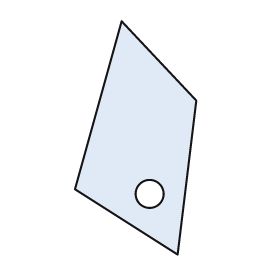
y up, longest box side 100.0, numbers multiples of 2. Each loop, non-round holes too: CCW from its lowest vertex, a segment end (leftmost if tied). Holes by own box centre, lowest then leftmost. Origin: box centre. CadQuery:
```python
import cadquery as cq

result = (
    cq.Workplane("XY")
    .moveTo(18.0, -50.0)
    .lineTo(26.0, 16.0)
    .lineTo(-6.0, 50.0)
    .lineTo(-26.0, -22.0)
    .close()
    .moveTo(6.0, -24.0)
    .circle(6.0)
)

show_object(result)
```